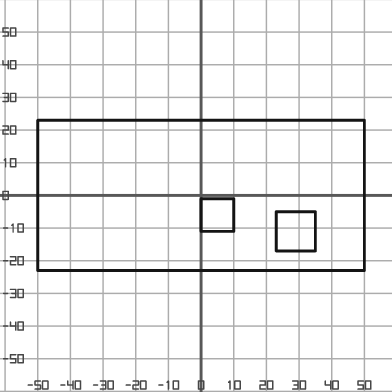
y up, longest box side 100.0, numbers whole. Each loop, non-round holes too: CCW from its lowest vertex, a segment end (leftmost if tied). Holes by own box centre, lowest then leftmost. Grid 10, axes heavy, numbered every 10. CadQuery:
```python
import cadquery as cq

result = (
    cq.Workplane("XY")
    .moveTo(-50.0, -23.0)
    .lineTo(50.0, -23.0)
    .lineTo(50.0, 23.0)
    .lineTo(-50.0, 23.0)
    .close()
    .moveTo(23.0, -17.0)
    .lineTo(35.0, -17.0)
    .lineTo(35.0, -5.0)
    .lineTo(23.0, -5.0)
    .close()
    .moveTo(0.0, -11.0)
    .lineTo(10.0, -11.0)
    .lineTo(10.0, -1.0)
    .lineTo(0.0, -1.0)
    .close()
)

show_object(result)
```